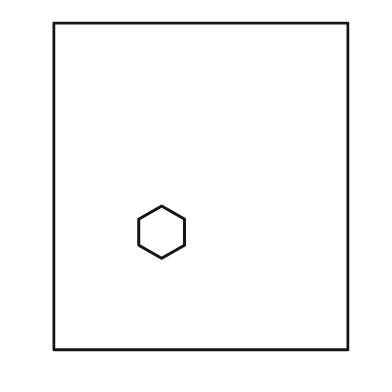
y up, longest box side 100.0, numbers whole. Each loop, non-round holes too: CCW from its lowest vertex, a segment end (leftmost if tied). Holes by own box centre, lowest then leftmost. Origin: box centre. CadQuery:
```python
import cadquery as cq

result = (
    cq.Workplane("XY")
    .moveTo(-45.0, -50.0)
    .lineTo(45.0, -50.0)
    .lineTo(45.0, 50.0)
    .lineTo(-45.0, 50.0)
    .close()
    .moveTo(-12.0, -22.0)
    .lineTo(-5.0, -18.0)
    .lineTo(-5.0, -10.0)
    .lineTo(-12.0, -6.0)
    .lineTo(-19.0, -10.0)
    .lineTo(-19.0, -18.0)
    .close()
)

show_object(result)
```